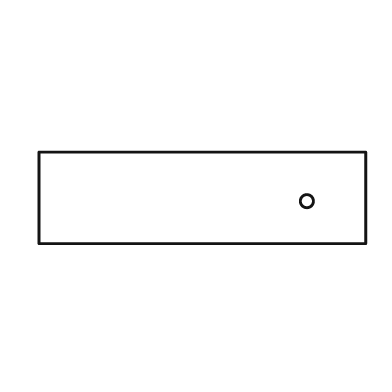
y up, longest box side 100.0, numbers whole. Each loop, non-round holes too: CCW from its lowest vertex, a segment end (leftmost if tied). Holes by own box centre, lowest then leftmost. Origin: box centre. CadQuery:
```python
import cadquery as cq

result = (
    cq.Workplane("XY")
    .moveTo(-50.0, -14.0)
    .lineTo(50.0, -14.0)
    .lineTo(50.0, 14.0)
    .lineTo(-50.0, 14.0)
    .close()
    .moveTo(32.0, -1.0)
    .circle(2.0)
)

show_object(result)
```